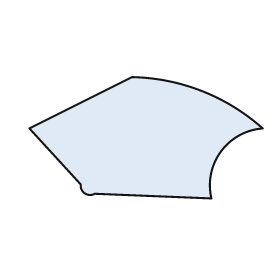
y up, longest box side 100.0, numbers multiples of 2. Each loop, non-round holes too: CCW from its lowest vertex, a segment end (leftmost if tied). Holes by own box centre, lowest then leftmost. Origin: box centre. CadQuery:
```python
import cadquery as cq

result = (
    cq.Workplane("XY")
    .moveTo(28.0, -26.0)
    .threePointArc((32.0, -6.0), (50.0, 4.0))
    .threePointArc((24.0, 20.0), (-6.0, 26.0))
    .lineTo(-50.0, 4.0)
    .lineTo(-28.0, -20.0)
    .threePointArc((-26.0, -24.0), (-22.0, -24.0))
    .close()
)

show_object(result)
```